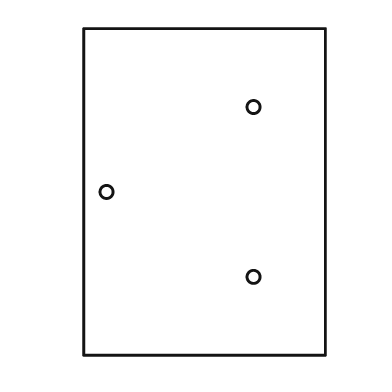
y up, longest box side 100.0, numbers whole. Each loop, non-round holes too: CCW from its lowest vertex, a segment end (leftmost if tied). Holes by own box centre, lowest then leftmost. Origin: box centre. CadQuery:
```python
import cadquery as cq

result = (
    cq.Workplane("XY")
    .moveTo(-37.0, -50.0)
    .lineTo(37.0, -50.0)
    .lineTo(37.0, 50.0)
    .lineTo(-37.0, 50.0)
    .close()
    .moveTo(15.0, -26.0)
    .circle(2.0)
    .moveTo(-30.0, 0.0)
    .circle(2.0)
    .moveTo(15.0, 26.0)
    .circle(2.0)
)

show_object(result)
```